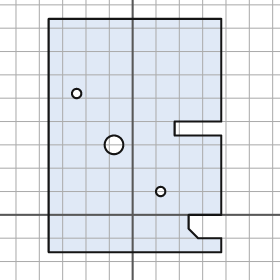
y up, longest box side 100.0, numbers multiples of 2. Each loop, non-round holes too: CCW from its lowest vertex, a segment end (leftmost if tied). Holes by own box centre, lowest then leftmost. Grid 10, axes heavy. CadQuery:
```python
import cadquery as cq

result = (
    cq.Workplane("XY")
    .moveTo(-36.0, -16.0)
    .lineTo(38.0, -16.0)
    .lineTo(38.0, -10.0)
    .lineTo(28.0, -10.0)
    .lineTo(24.0, -6.0)
    .lineTo(24.0, 0.0)
    .lineTo(38.0, 0.0)
    .lineTo(38.0, 34.0)
    .lineTo(18.0, 34.0)
    .lineTo(18.0, 40.0)
    .lineTo(38.0, 40.0)
    .lineTo(38.0, 84.0)
    .lineTo(-36.0, 84.0)
    .close()
    .moveTo(12.0, 10.0)
    .circle(2.0)
    .moveTo(-8.0, 30.0)
    .circle(4.0)
    .moveTo(-24.0, 52.0)
    .circle(2.0)
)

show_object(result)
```